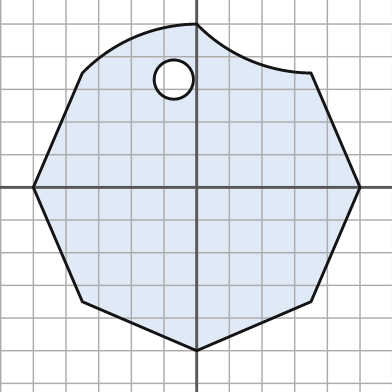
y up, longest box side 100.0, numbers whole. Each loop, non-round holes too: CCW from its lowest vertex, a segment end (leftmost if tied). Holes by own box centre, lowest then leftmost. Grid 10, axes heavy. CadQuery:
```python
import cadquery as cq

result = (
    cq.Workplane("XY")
    .moveTo(0.0, -50.0)
    .lineTo(35.0, -35.0)
    .lineTo(50.0, 0.0)
    .lineTo(35.0, 35.0)
    .threePointArc((16.0, 39.0), (0.0, 50.0))
    .threePointArc((-19.0, 46.0), (-35.0, 35.0))
    .lineTo(-50.0, 0.0)
    .lineTo(-35.0, -35.0)
    .close()
    .moveTo(-7.0, 33.0)
    .circle(6.0)
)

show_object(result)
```